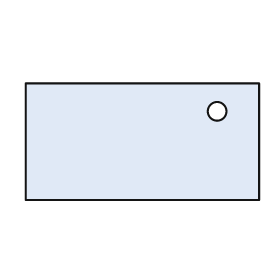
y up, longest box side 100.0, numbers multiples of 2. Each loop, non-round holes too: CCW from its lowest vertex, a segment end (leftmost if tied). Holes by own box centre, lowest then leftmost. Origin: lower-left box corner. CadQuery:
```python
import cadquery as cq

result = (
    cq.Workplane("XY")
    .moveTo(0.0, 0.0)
    .lineTo(100.0, 0.0)
    .lineTo(100.0, 50.0)
    .lineTo(0.0, 50.0)
    .close()
    .moveTo(82.0, 38.0)
    .circle(4.0)
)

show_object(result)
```